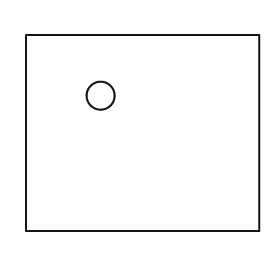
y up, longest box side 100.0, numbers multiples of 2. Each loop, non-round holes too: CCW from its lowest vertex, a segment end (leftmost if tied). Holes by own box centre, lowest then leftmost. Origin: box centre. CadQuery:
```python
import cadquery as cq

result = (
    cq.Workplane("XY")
    .moveTo(-50.0, -42.0)
    .lineTo(50.0, -42.0)
    .lineTo(50.0, 42.0)
    .lineTo(-50.0, 42.0)
    .close()
    .moveTo(-18.0, 16.0)
    .circle(6.0)
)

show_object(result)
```